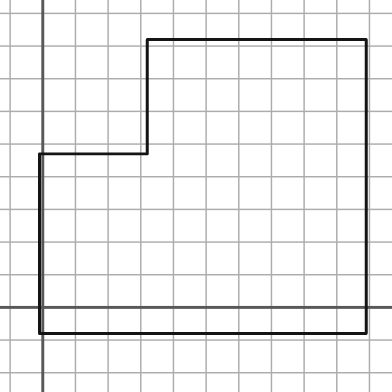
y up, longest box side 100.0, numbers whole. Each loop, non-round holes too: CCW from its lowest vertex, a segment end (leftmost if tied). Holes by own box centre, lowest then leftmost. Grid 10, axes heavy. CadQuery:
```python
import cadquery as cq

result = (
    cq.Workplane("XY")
    .moveTo(-1.0, -8.0)
    .lineTo(99.0, -8.0)
    .lineTo(99.0, 82.0)
    .lineTo(32.0, 82.0)
    .lineTo(32.0, 47.0)
    .lineTo(-1.0, 47.0)
    .close()
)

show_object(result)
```